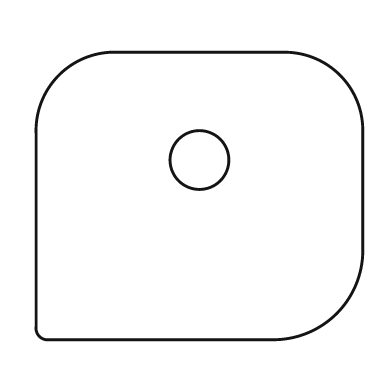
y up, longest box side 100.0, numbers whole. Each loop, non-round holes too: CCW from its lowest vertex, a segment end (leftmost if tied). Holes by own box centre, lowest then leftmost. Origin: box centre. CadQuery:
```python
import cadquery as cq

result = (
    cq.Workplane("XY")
    .moveTo(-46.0, -44.0)
    .lineTo(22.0, -44.0)
    .threePointArc((42.0, -36.0), (50.0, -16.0))
    .lineTo(50.0, 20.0)
    .threePointArc((43.0, 37.0), (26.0, 44.0))
    .lineTo(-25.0, 44.0)
    .threePointArc((-43.0, 37.0), (-50.0, 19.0))
    .lineTo(-50.0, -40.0)
    .threePointArc((-49.0, -43.0), (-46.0, -44.0))
    .close()
    .moveTo(0.0, 11.0)
    .circle(9.0)
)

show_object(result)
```